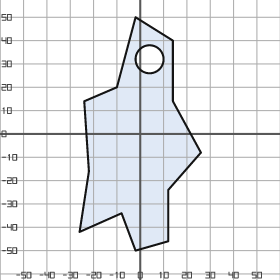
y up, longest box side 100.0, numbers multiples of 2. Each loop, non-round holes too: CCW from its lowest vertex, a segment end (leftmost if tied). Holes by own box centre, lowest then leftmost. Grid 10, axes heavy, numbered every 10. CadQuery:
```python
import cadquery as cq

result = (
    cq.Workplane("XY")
    .moveTo(-2.0, -50.0)
    .lineTo(12.0, -46.0)
    .lineTo(12.0, -24.0)
    .lineTo(26.0, -8.0)
    .lineTo(14.0, 14.0)
    .lineTo(14.0, 40.0)
    .lineTo(-2.0, 50.0)
    .lineTo(-10.0, 20.0)
    .lineTo(-24.0, 14.0)
    .lineTo(-22.0, -16.0)
    .lineTo(-26.0, -42.0)
    .lineTo(-8.0, -34.0)
    .close()
    .moveTo(4.0, 32.0)
    .circle(6.0)
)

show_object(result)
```